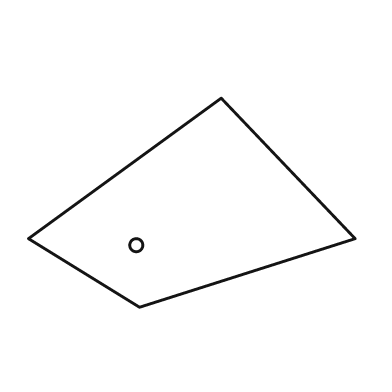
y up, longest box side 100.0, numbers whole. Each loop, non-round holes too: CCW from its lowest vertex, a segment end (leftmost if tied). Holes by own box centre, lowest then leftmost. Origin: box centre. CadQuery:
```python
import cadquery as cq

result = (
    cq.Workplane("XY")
    .moveTo(-16.0, -32.0)
    .lineTo(50.0, -11.0)
    .lineTo(9.0, 32.0)
    .lineTo(-50.0, -11.0)
    .close()
    .moveTo(-17.0, -13.0)
    .circle(2.0)
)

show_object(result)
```